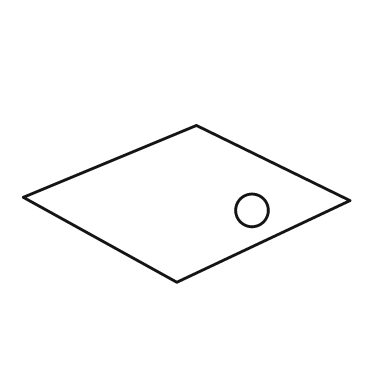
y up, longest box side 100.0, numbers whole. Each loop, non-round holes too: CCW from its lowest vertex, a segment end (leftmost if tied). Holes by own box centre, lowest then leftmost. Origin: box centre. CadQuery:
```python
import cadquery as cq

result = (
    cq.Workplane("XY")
    .moveTo(-3.0, -24.0)
    .lineTo(50.0, 1.0)
    .lineTo(3.0, 24.0)
    .lineTo(-50.0, 2.0)
    .close()
    .moveTo(20.0, -2.0)
    .circle(5.0)
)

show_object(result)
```